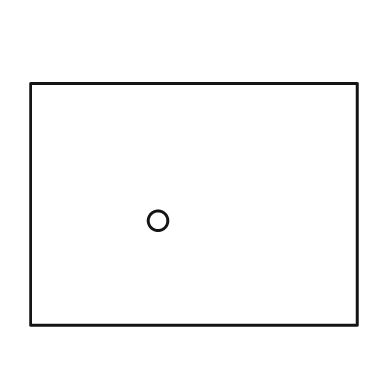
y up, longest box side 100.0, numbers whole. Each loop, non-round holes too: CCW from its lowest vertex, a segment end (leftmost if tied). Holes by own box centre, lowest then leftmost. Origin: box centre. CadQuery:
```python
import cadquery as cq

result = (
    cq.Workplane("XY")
    .moveTo(-50.0, -37.0)
    .lineTo(50.0, -37.0)
    .lineTo(50.0, 37.0)
    .lineTo(-50.0, 37.0)
    .close()
    .moveTo(-11.0, -5.0)
    .circle(3.0)
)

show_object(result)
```